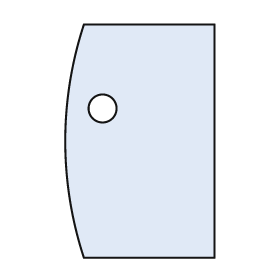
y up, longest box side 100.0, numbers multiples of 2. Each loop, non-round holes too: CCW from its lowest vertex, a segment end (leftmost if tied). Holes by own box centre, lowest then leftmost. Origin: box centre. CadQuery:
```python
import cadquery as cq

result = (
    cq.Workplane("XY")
    .moveTo(-24.0, -50.0)
    .lineTo(32.0, -50.0)
    .lineTo(32.0, 50.0)
    .lineTo(-24.0, 50.0)
    .threePointArc((-32.0, 0.0), (-24.0, -50.0))
    .close()
    .moveTo(-16.0, 14.0)
    .circle(6.0)
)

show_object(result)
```